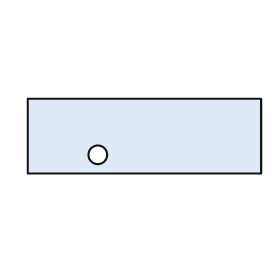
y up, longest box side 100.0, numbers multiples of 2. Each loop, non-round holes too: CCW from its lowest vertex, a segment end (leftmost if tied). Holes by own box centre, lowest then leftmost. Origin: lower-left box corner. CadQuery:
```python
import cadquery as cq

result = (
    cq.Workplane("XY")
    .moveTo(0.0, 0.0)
    .lineTo(100.0, 0.0)
    .lineTo(100.0, 32.0)
    .lineTo(0.0, 32.0)
    .close()
    .moveTo(30.0, 8.0)
    .circle(4.0)
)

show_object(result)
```